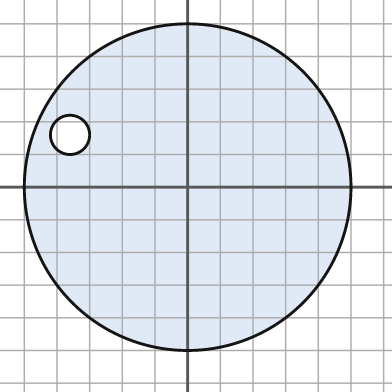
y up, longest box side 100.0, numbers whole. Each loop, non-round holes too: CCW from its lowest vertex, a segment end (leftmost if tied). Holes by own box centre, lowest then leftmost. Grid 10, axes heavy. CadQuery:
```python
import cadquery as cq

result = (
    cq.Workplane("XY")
    .moveTo(0.0, 0.0)
    .circle(50.0)
    .moveTo(-36.0, 16.0)
    .circle(6.0)
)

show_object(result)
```